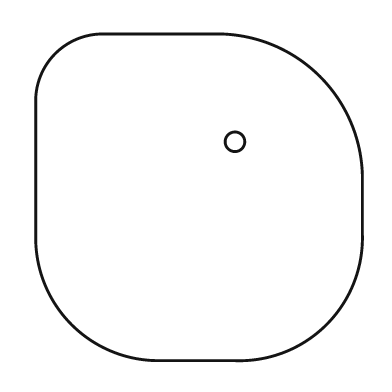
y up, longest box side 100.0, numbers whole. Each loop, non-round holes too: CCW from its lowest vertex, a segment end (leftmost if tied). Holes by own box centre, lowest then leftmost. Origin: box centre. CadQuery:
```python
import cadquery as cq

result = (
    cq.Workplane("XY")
    .moveTo(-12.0, -50.0)
    .lineTo(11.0, -50.0)
    .threePointArc((39.0, -39.0), (50.0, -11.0))
    .lineTo(50.0, 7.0)
    .threePointArc((37.0, 37.0), (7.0, 50.0))
    .lineTo(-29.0, 50.0)
    .threePointArc((-44.0, 44.0), (-50.0, 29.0))
    .lineTo(-50.0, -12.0)
    .threePointArc((-39.0, -39.0), (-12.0, -50.0))
    .close()
    .moveTo(11.0, 17.0)
    .circle(3.0)
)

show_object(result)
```